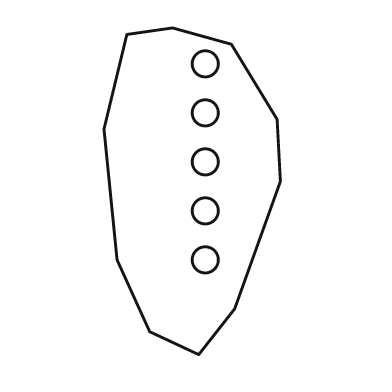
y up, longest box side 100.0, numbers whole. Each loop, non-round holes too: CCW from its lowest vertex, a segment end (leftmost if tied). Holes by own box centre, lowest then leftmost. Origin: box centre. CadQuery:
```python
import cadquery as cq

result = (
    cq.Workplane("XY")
    .moveTo(2.0, -50.0)
    .lineTo(13.0, -36.0)
    .lineTo(27.0, 3.0)
    .lineTo(26.0, 22.0)
    .lineTo(12.0, 45.0)
    .lineTo(-6.0, 50.0)
    .lineTo(-20.0, 48.0)
    .lineTo(-27.0, 19.0)
    .lineTo(-23.0, -21.0)
    .lineTo(-13.0, -43.0)
    .close()
    .moveTo(4.0, -21.0)
    .circle(4.0)
    .moveTo(4.0, -6.0)
    .circle(4.0)
    .moveTo(4.0, 9.0)
    .circle(4.0)
    .moveTo(4.0, 24.0)
    .circle(4.0)
    .moveTo(4.0, 39.0)
    .circle(4.0)
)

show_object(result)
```